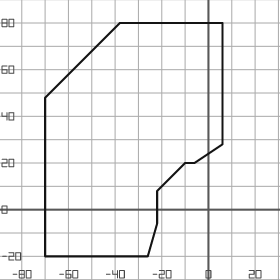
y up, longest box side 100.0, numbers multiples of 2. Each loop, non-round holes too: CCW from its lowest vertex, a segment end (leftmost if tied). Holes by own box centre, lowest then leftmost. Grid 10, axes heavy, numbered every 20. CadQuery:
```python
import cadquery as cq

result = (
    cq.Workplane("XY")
    .moveTo(-70.0, -20.0)
    .lineTo(-26.0, -20.0)
    .lineTo(-22.0, -6.0)
    .lineTo(-22.0, 8.0)
    .lineTo(-10.0, 20.0)
    .lineTo(-6.0, 20.0)
    .lineTo(6.0, 28.0)
    .lineTo(6.0, 80.0)
    .lineTo(-38.0, 80.0)
    .lineTo(-70.0, 48.0)
    .close()
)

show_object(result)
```